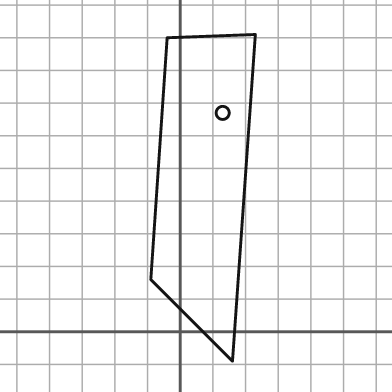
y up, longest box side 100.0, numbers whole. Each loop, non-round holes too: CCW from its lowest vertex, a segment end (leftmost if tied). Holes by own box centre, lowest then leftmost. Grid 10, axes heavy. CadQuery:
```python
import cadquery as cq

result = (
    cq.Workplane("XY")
    .moveTo(16.0, -9.0)
    .lineTo(23.0, 91.0)
    .lineTo(-4.0, 90.0)
    .lineTo(-9.0, 16.0)
    .close()
    .moveTo(13.0, 67.0)
    .circle(2.0)
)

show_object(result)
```